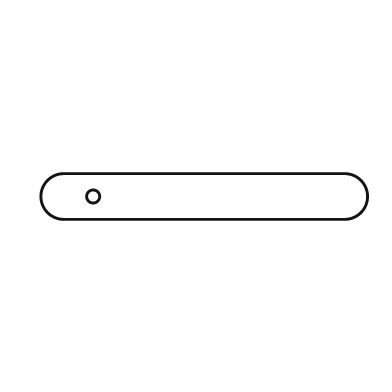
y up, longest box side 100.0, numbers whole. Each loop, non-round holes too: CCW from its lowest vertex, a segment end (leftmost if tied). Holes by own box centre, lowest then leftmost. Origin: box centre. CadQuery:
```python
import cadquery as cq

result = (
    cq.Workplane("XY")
    .moveTo(-43.0, -7.0)
    .lineTo(43.0, -7.0)
    .threePointArc((50.0, 0.0), (43.0, 7.0))
    .lineTo(-43.0, 7.0)
    .threePointArc((-50.0, 0.0), (-43.0, -7.0))
    .close()
    .moveTo(-34.0, 0.0)
    .circle(2.0)
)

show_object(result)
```